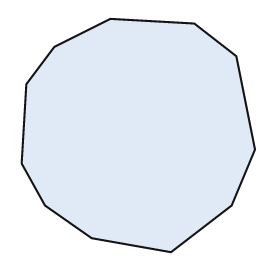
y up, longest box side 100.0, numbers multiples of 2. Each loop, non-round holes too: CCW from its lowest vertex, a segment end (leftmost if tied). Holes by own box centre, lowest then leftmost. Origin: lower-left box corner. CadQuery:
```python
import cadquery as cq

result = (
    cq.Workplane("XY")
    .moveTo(64.0, 0.0)
    .lineTo(90.0, 20.0)
    .lineTo(100.0, 44.0)
    .lineTo(92.0, 84.0)
    .lineTo(74.0, 98.0)
    .lineTo(38.0, 100.0)
    .lineTo(14.0, 88.0)
    .lineTo(2.0, 72.0)
    .lineTo(0.0, 38.0)
    .lineTo(10.0, 20.0)
    .lineTo(30.0, 6.0)
    .close()
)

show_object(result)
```